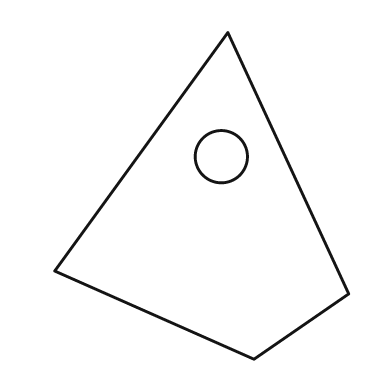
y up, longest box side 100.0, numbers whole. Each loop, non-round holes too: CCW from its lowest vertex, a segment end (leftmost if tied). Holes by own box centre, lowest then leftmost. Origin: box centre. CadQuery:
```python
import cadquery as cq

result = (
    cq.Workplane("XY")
    .moveTo(16.0, -50.0)
    .lineTo(45.0, -30.0)
    .lineTo(8.0, 50.0)
    .lineTo(-45.0, -23.0)
    .close()
    .moveTo(6.0, 12.0)
    .circle(8.0)
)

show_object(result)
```